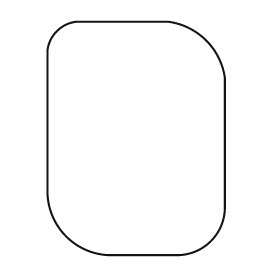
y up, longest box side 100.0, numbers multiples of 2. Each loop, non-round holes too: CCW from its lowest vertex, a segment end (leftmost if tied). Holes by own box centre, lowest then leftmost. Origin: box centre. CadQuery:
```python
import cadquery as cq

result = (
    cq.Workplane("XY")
    .moveTo(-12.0, -50.0)
    .lineTo(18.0, -50.0)
    .threePointArc((32.0, -44.0), (38.0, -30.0))
    .lineTo(38.0, 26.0)
    .threePointArc((30.0, 42.0), (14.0, 50.0))
    .lineTo(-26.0, 50.0)
    .threePointArc((-34.0, 46.0), (-38.0, 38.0))
    .lineTo(-38.0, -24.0)
    .threePointArc((-30.0, -42.0), (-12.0, -50.0))
    .close()
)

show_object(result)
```